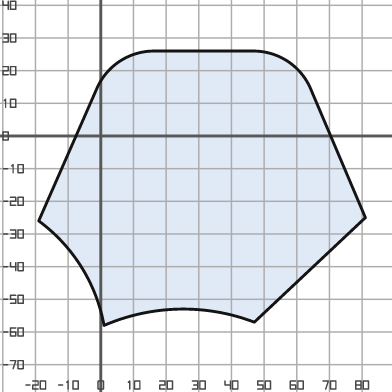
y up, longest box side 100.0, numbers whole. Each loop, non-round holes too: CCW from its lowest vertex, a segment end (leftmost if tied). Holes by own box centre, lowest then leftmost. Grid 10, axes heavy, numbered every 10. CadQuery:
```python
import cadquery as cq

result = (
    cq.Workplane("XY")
    .moveTo(1.0, -58.0)
    .threePointArc((24.0, -53.0), (47.0, -57.0))
    .lineTo(81.0, -25.0)
    .lineTo(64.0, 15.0)
    .threePointArc((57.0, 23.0), (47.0, 26.0))
    .lineTo(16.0, 26.0)
    .threePointArc((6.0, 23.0), (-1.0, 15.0))
    .lineTo(-19.0, -26.0)
    .threePointArc((-6.0, -40.0), (1.0, -58.0))
    .close()
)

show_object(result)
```